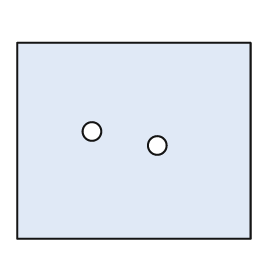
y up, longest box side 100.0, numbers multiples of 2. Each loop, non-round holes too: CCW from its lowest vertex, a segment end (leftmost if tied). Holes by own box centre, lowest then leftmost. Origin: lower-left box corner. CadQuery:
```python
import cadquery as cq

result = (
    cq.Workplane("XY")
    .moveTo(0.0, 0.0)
    .lineTo(100.0, 0.0)
    .lineTo(100.0, 84.0)
    .lineTo(0.0, 84.0)
    .close()
    .moveTo(60.0, 40.0)
    .circle(4.0)
    .moveTo(32.0, 46.0)
    .circle(4.0)
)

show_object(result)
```